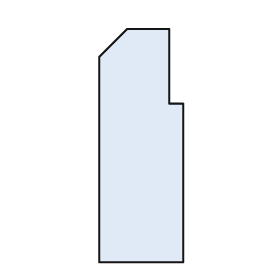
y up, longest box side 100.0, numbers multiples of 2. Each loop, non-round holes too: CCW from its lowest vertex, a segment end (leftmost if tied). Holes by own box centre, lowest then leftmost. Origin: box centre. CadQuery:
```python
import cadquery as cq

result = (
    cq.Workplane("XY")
    .moveTo(-18.0, -50.0)
    .lineTo(18.0, -50.0)
    .lineTo(18.0, 18.0)
    .lineTo(12.0, 18.0)
    .lineTo(12.0, 50.0)
    .lineTo(-6.0, 50.0)
    .lineTo(-18.0, 38.0)
    .close()
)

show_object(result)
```